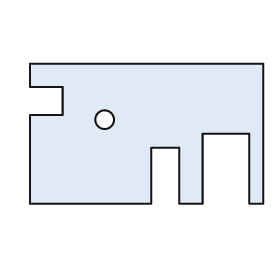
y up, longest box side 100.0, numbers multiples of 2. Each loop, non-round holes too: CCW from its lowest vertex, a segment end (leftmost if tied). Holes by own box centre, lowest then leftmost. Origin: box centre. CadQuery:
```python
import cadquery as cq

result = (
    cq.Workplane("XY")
    .moveTo(-50.0, -30.0)
    .lineTo(2.0, -30.0)
    .lineTo(2.0, -6.0)
    .lineTo(14.0, -6.0)
    .lineTo(14.0, -30.0)
    .lineTo(24.0, -30.0)
    .lineTo(24.0, 0.0)
    .lineTo(44.0, 0.0)
    .lineTo(44.0, -30.0)
    .lineTo(50.0, -30.0)
    .lineTo(50.0, 30.0)
    .lineTo(-50.0, 30.0)
    .lineTo(-50.0, 20.0)
    .lineTo(-36.0, 20.0)
    .lineTo(-36.0, 8.0)
    .lineTo(-50.0, 8.0)
    .close()
    .moveTo(-18.0, 6.0)
    .circle(4.0)
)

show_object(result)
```